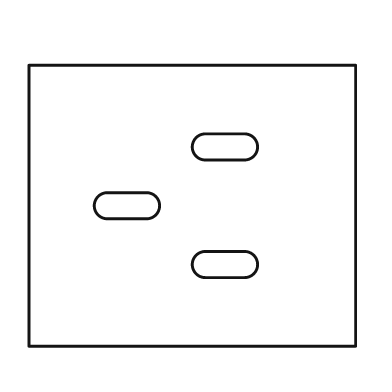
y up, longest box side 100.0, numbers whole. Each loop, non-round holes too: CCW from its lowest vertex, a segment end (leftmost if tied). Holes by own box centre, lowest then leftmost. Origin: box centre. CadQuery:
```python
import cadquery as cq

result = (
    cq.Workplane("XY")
    .moveTo(-50.0, -43.0)
    .lineTo(50.0, -43.0)
    .lineTo(50.0, 43.0)
    .lineTo(-50.0, 43.0)
    .close()
    .moveTo(4.0, -22.0)
    .lineTo(16.0, -22.0)
    .threePointArc((20.0, -18.0), (16.0, -14.0))
    .lineTo(4.0, -14.0)
    .threePointArc((0.0, -18.0), (4.0, -22.0))
    .close()
    .moveTo(-26.0, -4.0)
    .lineTo(-14.0, -4.0)
    .threePointArc((-10.0, 0.0), (-14.0, 4.0))
    .lineTo(-26.0, 4.0)
    .threePointArc((-30.0, 0.0), (-26.0, -4.0))
    .close()
    .moveTo(4.0, 14.0)
    .lineTo(16.0, 14.0)
    .threePointArc((20.0, 18.0), (16.0, 22.0))
    .lineTo(4.0, 22.0)
    .threePointArc((0.0, 18.0), (4.0, 14.0))
    .close()
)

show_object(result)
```